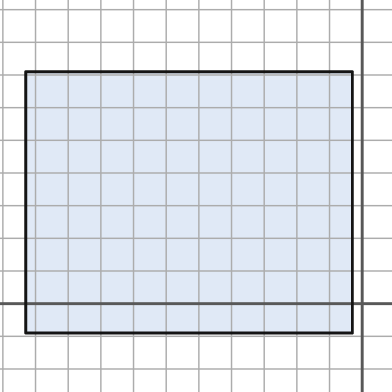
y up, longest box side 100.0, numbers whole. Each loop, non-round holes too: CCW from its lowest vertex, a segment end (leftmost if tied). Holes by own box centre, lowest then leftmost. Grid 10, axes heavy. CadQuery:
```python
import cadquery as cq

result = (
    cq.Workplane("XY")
    .moveTo(-103.0, -9.0)
    .lineTo(-3.0, -9.0)
    .lineTo(-3.0, 71.0)
    .lineTo(-103.0, 71.0)
    .close()
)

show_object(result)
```